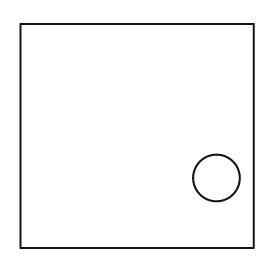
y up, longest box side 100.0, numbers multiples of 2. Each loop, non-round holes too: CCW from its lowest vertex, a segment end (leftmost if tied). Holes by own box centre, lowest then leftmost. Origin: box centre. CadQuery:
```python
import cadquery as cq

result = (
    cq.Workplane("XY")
    .moveTo(-50.0, -48.0)
    .lineTo(50.0, -48.0)
    .lineTo(50.0, 48.0)
    .lineTo(-50.0, 48.0)
    .close()
    .moveTo(34.0, -18.0)
    .circle(10.0)
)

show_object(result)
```